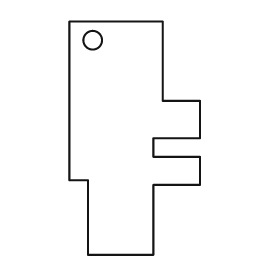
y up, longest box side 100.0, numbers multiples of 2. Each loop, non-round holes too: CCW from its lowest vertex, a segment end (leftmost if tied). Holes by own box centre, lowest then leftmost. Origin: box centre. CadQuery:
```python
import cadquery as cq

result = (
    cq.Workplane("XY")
    .moveTo(-20.0, -50.0)
    .lineTo(8.0, -50.0)
    .lineTo(8.0, -20.0)
    .lineTo(28.0, -20.0)
    .lineTo(28.0, -8.0)
    .lineTo(8.0, -8.0)
    .lineTo(8.0, 0.0)
    .lineTo(28.0, 0.0)
    .lineTo(28.0, 16.0)
    .lineTo(12.0, 16.0)
    .lineTo(12.0, 50.0)
    .lineTo(-28.0, 50.0)
    .lineTo(-28.0, -18.0)
    .lineTo(-20.0, -18.0)
    .close()
    .moveTo(-18.0, 42.0)
    .circle(4.0)
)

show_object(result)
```